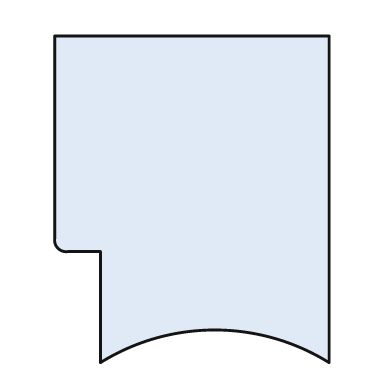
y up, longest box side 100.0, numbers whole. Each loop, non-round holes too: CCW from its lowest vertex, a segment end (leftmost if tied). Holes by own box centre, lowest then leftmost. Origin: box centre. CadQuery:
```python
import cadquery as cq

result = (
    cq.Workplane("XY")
    .moveTo(-28.0, -50.0)
    .threePointArc((7.0, -40.0), (42.0, -50.0))
    .lineTo(42.0, 50.0)
    .lineTo(-42.0, 50.0)
    .lineTo(-42.0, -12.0)
    .threePointArc((-41.0, -15.0), (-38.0, -16.0))
    .lineTo(-28.0, -16.0)
    .close()
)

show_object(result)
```